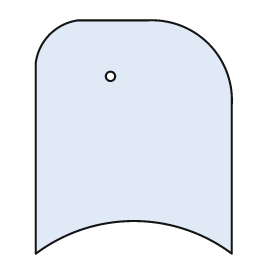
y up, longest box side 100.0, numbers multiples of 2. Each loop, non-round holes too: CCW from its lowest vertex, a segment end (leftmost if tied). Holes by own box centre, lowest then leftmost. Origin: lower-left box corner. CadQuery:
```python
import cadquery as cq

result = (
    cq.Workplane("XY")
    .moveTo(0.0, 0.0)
    .threePointArc((42.0, 14.0), (84.0, 0.0))
    .lineTo(84.0, 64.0)
    .threePointArc((74.0, 90.0), (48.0, 100.0))
    .lineTo(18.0, 100.0)
    .threePointArc((6.0, 94.0), (0.0, 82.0))
    .close()
    .moveTo(32.0, 76.0)
    .circle(2.0)
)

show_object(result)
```